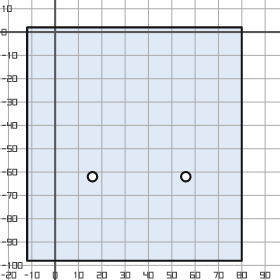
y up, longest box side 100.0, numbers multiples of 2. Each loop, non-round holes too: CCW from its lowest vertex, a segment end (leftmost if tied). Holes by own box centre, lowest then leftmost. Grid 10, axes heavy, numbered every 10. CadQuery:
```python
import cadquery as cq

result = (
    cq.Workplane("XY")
    .moveTo(-12.0, -98.0)
    .lineTo(80.0, -98.0)
    .lineTo(80.0, 2.0)
    .lineTo(-12.0, 2.0)
    .close()
    .moveTo(16.0, -62.0)
    .circle(2.0)
    .moveTo(56.0, -62.0)
    .circle(2.0)
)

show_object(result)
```